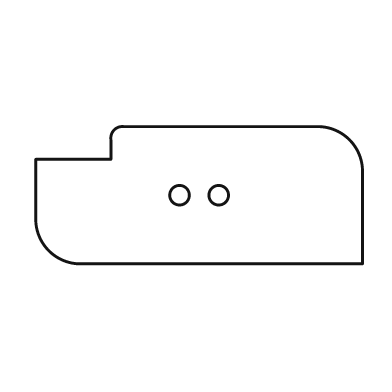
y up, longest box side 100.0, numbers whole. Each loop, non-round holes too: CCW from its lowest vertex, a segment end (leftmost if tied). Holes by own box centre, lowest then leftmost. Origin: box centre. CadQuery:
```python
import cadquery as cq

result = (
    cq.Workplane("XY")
    .moveTo(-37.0, -21.0)
    .lineTo(50.0, -21.0)
    .lineTo(50.0, 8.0)
    .threePointArc((46.0, 17.0), (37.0, 21.0))
    .lineTo(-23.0, 21.0)
    .threePointArc((-26.0, 20.0), (-27.0, 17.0))
    .lineTo(-27.0, 11.0)
    .lineTo(-50.0, 11.0)
    .lineTo(-50.0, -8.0)
    .threePointArc((-46.0, -17.0), (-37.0, -21.0))
    .close()
    .moveTo(-6.0, 0.0)
    .circle(3.0)
    .moveTo(6.0, 0.0)
    .circle(3.0)
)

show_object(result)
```